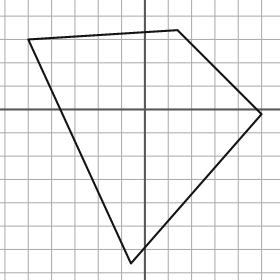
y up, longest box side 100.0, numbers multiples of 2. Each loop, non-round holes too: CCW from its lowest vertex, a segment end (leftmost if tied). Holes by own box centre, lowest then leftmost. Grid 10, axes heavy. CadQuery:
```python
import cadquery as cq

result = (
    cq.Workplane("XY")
    .moveTo(-6.0, -66.0)
    .lineTo(50.0, -2.0)
    .lineTo(14.0, 34.0)
    .lineTo(-50.0, 30.0)
    .close()
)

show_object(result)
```